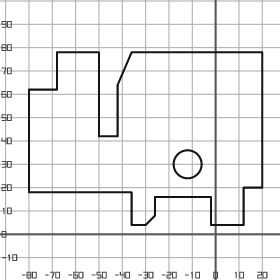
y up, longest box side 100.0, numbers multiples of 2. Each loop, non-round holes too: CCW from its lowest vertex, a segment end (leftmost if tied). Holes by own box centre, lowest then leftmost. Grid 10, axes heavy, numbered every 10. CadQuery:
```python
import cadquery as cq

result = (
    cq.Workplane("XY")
    .moveTo(-36.0, 4.0)
    .lineTo(-30.0, 4.0)
    .lineTo(-26.0, 8.0)
    .lineTo(-26.0, 16.0)
    .lineTo(-2.0, 16.0)
    .lineTo(-2.0, 4.0)
    .lineTo(12.0, 4.0)
    .lineTo(12.0, 20.0)
    .lineTo(20.0, 20.0)
    .lineTo(20.0, 78.0)
    .lineTo(-36.0, 78.0)
    .lineTo(-42.0, 64.0)
    .lineTo(-42.0, 42.0)
    .lineTo(-50.0, 42.0)
    .lineTo(-50.0, 78.0)
    .lineTo(-68.0, 78.0)
    .lineTo(-68.0, 62.0)
    .lineTo(-80.0, 62.0)
    .lineTo(-80.0, 18.0)
    .lineTo(-36.0, 18.0)
    .close()
    .moveTo(-12.0, 30.0)
    .circle(6.0)
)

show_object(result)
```